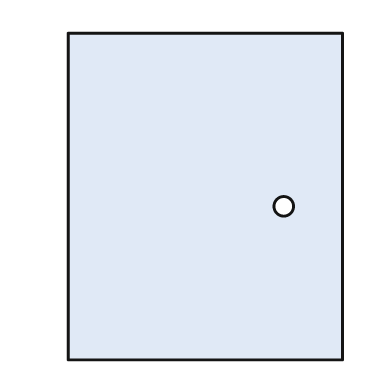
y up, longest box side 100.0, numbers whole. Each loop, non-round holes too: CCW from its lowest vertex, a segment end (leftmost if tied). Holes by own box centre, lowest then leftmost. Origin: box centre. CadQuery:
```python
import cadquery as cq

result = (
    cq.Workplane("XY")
    .moveTo(-42.0, -50.0)
    .lineTo(42.0, -50.0)
    .lineTo(42.0, 50.0)
    .lineTo(-42.0, 50.0)
    .close()
    .moveTo(24.0, -3.0)
    .circle(3.0)
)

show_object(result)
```